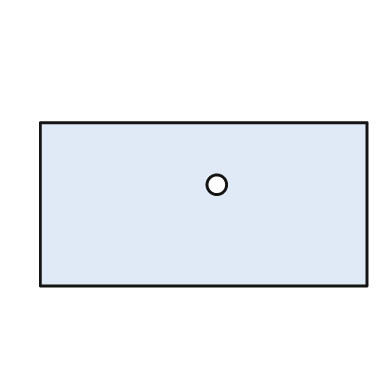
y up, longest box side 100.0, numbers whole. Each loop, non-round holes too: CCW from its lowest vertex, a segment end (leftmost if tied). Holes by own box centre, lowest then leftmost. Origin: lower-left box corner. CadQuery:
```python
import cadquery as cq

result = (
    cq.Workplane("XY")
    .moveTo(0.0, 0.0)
    .lineTo(100.0, 0.0)
    .lineTo(100.0, 50.0)
    .lineTo(0.0, 50.0)
    .close()
    .moveTo(54.0, 31.0)
    .circle(3.0)
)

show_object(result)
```